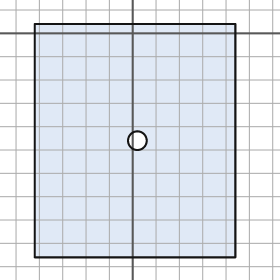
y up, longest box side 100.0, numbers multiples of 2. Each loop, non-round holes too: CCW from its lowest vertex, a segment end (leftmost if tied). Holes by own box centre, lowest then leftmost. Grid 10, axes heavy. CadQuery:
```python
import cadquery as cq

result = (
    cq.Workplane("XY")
    .moveTo(-42.0, -96.0)
    .lineTo(44.0, -96.0)
    .lineTo(44.0, 4.0)
    .lineTo(-42.0, 4.0)
    .close()
    .moveTo(2.0, -46.0)
    .circle(4.0)
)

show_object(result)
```